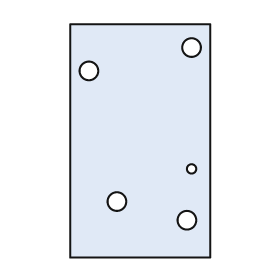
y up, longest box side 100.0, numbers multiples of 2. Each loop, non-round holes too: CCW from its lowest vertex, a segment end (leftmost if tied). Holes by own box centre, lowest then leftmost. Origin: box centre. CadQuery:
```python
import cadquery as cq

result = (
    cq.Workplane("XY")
    .moveTo(-30.0, -50.0)
    .lineTo(30.0, -50.0)
    .lineTo(30.0, 50.0)
    .lineTo(-30.0, 50.0)
    .close()
    .moveTo(20.0, -34.0)
    .circle(4.0)
    .moveTo(-10.0, -26.0)
    .circle(4.0)
    .moveTo(22.0, -12.0)
    .circle(2.0)
    .moveTo(-22.0, 30.0)
    .circle(4.0)
    .moveTo(22.0, 40.0)
    .circle(4.0)
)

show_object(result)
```